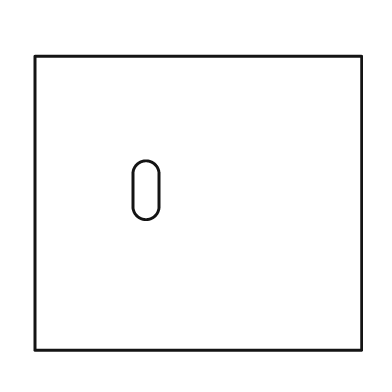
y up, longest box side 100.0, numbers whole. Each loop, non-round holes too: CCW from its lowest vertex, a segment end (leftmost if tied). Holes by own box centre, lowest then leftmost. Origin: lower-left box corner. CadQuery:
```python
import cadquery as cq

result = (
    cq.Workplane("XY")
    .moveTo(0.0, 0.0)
    .lineTo(100.0, 0.0)
    .lineTo(100.0, 90.0)
    .lineTo(0.0, 90.0)
    .close()
    .moveTo(30.0, 44.0)
    .threePointArc((34.0, 40.0), (38.0, 44.0))
    .lineTo(38.0, 54.0)
    .threePointArc((34.0, 58.0), (30.0, 54.0))
    .close()
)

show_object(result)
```